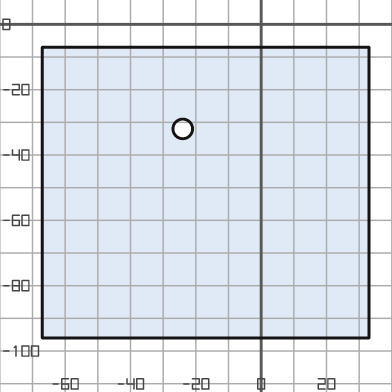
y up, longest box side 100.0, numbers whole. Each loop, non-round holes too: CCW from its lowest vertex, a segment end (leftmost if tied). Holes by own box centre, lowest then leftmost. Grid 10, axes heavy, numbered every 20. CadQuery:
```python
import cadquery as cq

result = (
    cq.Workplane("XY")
    .moveTo(-67.0, -96.0)
    .lineTo(33.0, -96.0)
    .lineTo(33.0, -7.0)
    .lineTo(-67.0, -7.0)
    .close()
    .moveTo(-24.0, -32.0)
    .circle(3.0)
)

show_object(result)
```